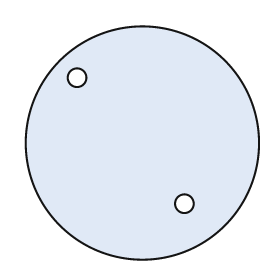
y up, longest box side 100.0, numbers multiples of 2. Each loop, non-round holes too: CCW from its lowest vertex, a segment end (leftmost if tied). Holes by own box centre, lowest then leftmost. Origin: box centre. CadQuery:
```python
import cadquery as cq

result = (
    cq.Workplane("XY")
    .moveTo(0.0, 0.0)
    .circle(50.0)
    .moveTo(18.0, -26.0)
    .circle(4.0)
    .moveTo(-28.0, 28.0)
    .circle(4.0)
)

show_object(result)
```